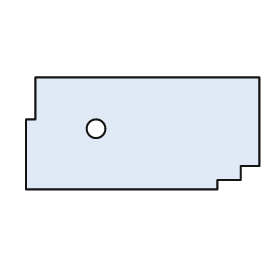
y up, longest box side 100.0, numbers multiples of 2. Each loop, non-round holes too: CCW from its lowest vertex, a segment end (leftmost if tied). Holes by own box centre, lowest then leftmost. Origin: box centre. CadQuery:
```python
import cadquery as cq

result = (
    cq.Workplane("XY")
    .moveTo(-50.0, -24.0)
    .lineTo(32.0, -24.0)
    .lineTo(32.0, -20.0)
    .lineTo(42.0, -20.0)
    .lineTo(42.0, -14.0)
    .lineTo(50.0, -14.0)
    .lineTo(50.0, 24.0)
    .lineTo(-46.0, 24.0)
    .lineTo(-46.0, 6.0)
    .lineTo(-50.0, 6.0)
    .close()
    .moveTo(-20.0, 2.0)
    .circle(4.0)
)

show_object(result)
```